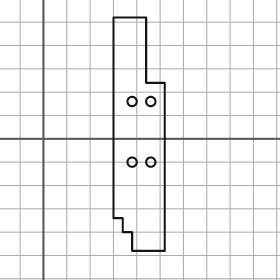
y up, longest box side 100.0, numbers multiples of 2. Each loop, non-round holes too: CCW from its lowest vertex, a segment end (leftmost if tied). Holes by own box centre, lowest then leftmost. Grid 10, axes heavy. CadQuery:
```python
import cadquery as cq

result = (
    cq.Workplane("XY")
    .moveTo(38.0, -48.0)
    .lineTo(52.0, -48.0)
    .lineTo(52.0, 24.0)
    .lineTo(44.0, 24.0)
    .lineTo(44.0, 52.0)
    .lineTo(30.0, 52.0)
    .lineTo(30.0, -34.0)
    .lineTo(34.0, -34.0)
    .lineTo(34.0, -40.0)
    .lineTo(38.0, -40.0)
    .close()
    .moveTo(38.0, -10.0)
    .circle(2.0)
    .moveTo(46.0, -10.0)
    .circle(2.0)
    .moveTo(38.0, 16.0)
    .circle(2.0)
    .moveTo(46.0, 16.0)
    .circle(2.0)
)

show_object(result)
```